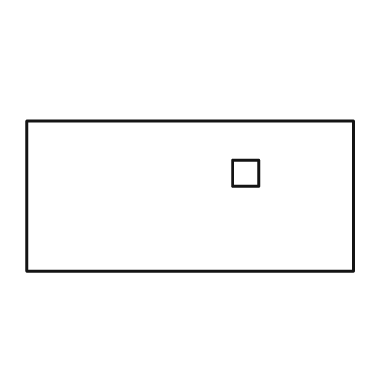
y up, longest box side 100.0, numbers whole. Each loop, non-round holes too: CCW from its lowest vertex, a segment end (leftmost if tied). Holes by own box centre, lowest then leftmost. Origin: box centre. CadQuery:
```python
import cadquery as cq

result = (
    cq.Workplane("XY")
    .moveTo(-50.0, -23.0)
    .lineTo(50.0, -23.0)
    .lineTo(50.0, 23.0)
    .lineTo(-50.0, 23.0)
    .close()
    .moveTo(13.0, 3.0)
    .lineTo(21.0, 3.0)
    .lineTo(21.0, 11.0)
    .lineTo(13.0, 11.0)
    .close()
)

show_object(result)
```